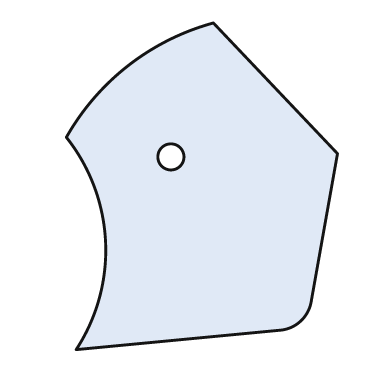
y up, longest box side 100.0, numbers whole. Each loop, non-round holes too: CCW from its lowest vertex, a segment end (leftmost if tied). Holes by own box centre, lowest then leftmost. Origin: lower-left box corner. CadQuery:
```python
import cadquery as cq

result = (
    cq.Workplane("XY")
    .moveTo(3.0, 0.0)
    .lineTo(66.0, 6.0)
    .threePointArc((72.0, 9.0), (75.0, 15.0))
    .lineTo(83.0, 60.0)
    .lineTo(45.0, 100.0)
    .threePointArc((19.0, 87.0), (0.0, 65.0))
    .threePointArc((12.0, 33.0), (3.0, 0.0))
    .close()
    .moveTo(32.0, 59.0)
    .circle(4.0)
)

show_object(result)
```